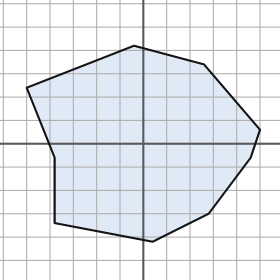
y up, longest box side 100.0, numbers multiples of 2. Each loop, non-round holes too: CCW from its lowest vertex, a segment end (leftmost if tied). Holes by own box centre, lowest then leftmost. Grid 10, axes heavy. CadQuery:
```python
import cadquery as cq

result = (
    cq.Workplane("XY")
    .moveTo(4.0, -42.0)
    .lineTo(28.0, -30.0)
    .lineTo(46.0, -6.0)
    .lineTo(50.0, 6.0)
    .lineTo(26.0, 34.0)
    .lineTo(-4.0, 42.0)
    .lineTo(-50.0, 24.0)
    .lineTo(-38.0, -6.0)
    .lineTo(-38.0, -34.0)
    .close()
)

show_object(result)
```